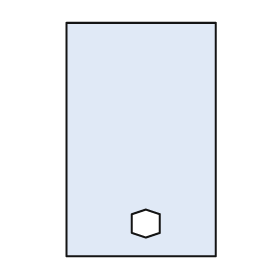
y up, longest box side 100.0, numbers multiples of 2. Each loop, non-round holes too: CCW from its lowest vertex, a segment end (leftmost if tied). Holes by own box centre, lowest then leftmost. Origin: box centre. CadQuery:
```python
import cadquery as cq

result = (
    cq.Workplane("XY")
    .moveTo(-32.0, -50.0)
    .lineTo(32.0, -50.0)
    .lineTo(32.0, 50.0)
    .lineTo(-32.0, 50.0)
    .close()
    .moveTo(2.0, -42.0)
    .lineTo(8.0, -40.0)
    .lineTo(8.0, -32.0)
    .lineTo(2.0, -30.0)
    .lineTo(-4.0, -32.0)
    .lineTo(-4.0, -40.0)
    .close()
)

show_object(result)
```